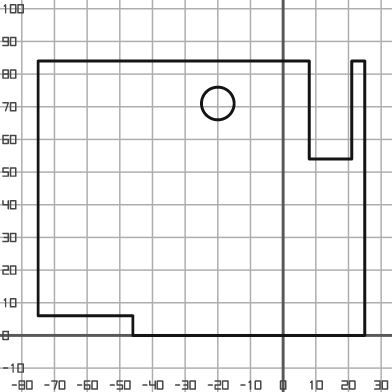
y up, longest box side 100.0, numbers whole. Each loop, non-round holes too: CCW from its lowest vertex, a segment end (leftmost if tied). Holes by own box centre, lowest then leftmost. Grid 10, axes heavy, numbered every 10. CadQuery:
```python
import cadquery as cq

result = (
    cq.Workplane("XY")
    .moveTo(-46.0, 0.0)
    .lineTo(25.0, 0.0)
    .lineTo(25.0, 84.0)
    .lineTo(21.0, 84.0)
    .lineTo(21.0, 54.0)
    .lineTo(8.0, 54.0)
    .lineTo(8.0, 84.0)
    .lineTo(-75.0, 84.0)
    .lineTo(-75.0, 6.0)
    .lineTo(-46.0, 6.0)
    .close()
    .moveTo(-20.0, 71.0)
    .circle(5.0)
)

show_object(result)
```